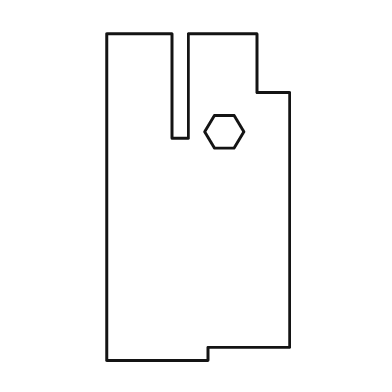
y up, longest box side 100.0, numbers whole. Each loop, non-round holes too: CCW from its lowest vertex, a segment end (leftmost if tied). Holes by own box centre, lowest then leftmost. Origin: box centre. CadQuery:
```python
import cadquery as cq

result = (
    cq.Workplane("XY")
    .moveTo(-28.0, -50.0)
    .lineTo(3.0, -50.0)
    .lineTo(3.0, -46.0)
    .lineTo(28.0, -46.0)
    .lineTo(28.0, 32.0)
    .lineTo(18.0, 32.0)
    .lineTo(18.0, 50.0)
    .lineTo(-3.0, 50.0)
    .lineTo(-3.0, 18.0)
    .lineTo(-8.0, 18.0)
    .lineTo(-8.0, 50.0)
    .lineTo(-28.0, 50.0)
    .close()
    .moveTo(5.0, 15.0)
    .lineTo(11.0, 15.0)
    .lineTo(14.0, 20.0)
    .lineTo(11.0, 25.0)
    .lineTo(5.0, 25.0)
    .lineTo(2.0, 20.0)
    .close()
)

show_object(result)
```